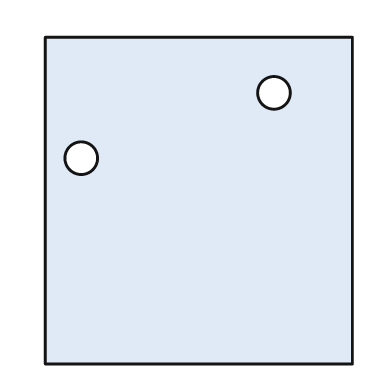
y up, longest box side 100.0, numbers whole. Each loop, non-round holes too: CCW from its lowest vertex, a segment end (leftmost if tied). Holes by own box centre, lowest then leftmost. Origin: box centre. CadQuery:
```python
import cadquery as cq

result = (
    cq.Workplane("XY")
    .moveTo(-47.0, -50.0)
    .lineTo(47.0, -50.0)
    .lineTo(47.0, 50.0)
    .lineTo(-47.0, 50.0)
    .close()
    .moveTo(-36.0, 13.0)
    .circle(5.0)
    .moveTo(23.0, 33.0)
    .circle(5.0)
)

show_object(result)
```